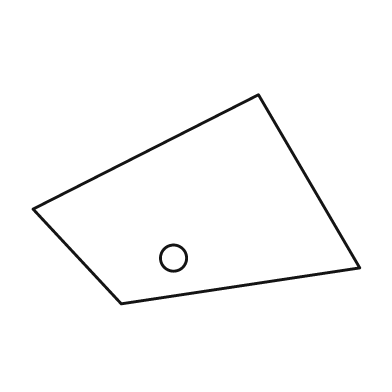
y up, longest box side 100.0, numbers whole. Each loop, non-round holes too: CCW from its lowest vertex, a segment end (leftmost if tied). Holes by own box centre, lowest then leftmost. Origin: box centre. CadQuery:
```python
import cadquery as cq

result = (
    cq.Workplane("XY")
    .moveTo(-23.0, -32.0)
    .lineTo(50.0, -21.0)
    .lineTo(19.0, 32.0)
    .lineTo(-50.0, -3.0)
    .close()
    .moveTo(-7.0, -18.0)
    .circle(4.0)
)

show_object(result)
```